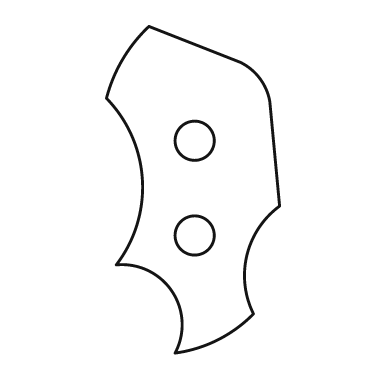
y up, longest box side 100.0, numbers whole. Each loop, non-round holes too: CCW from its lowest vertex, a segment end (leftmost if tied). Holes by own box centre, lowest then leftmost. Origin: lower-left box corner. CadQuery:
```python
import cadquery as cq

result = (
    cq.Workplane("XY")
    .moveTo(21.0, 0.0)
    .threePointArc((34.0, 4.0), (45.0, 12.0))
    .threePointArc((43.0, 30.0), (53.0, 45.0))
    .lineTo(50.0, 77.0)
    .threePointArc((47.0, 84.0), (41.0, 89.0))
    .lineTo(13.0, 100.0)
    .threePointArc((5.0, 90.0), (0.0, 78.0))
    .threePointArc((11.0, 53.0), (3.0, 27.0))
    .threePointArc((20.0, 19.0), (21.0, 0.0))
    .close()
    .moveTo(27.0, 36.0)
    .circle(6.0)
    .moveTo(27.0, 65.0)
    .circle(6.0)
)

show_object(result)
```